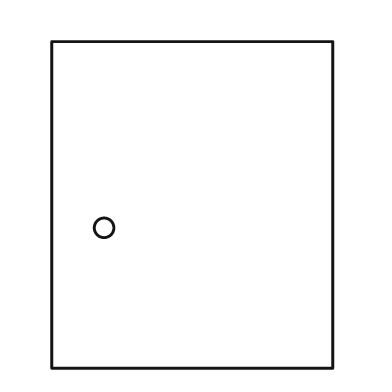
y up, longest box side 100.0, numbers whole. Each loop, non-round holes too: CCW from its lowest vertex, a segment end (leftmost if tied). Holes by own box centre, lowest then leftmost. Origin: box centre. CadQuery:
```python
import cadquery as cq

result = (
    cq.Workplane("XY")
    .moveTo(-43.0, -50.0)
    .lineTo(43.0, -50.0)
    .lineTo(43.0, 50.0)
    .lineTo(-43.0, 50.0)
    .close()
    .moveTo(-27.0, -7.0)
    .circle(3.0)
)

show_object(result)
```